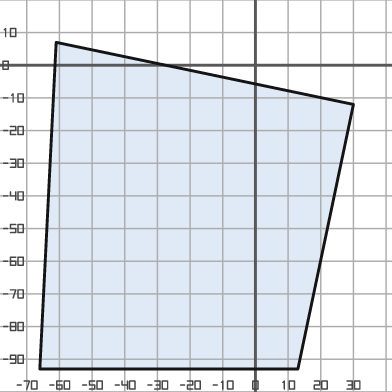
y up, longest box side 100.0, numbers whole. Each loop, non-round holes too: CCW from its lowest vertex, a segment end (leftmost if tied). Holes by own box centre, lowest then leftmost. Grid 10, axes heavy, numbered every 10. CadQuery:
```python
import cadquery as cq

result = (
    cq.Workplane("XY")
    .moveTo(-66.0, -93.0)
    .lineTo(13.0, -93.0)
    .lineTo(30.0, -12.0)
    .lineTo(-61.0, 7.0)
    .close()
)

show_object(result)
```